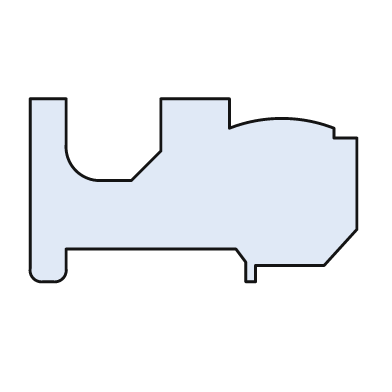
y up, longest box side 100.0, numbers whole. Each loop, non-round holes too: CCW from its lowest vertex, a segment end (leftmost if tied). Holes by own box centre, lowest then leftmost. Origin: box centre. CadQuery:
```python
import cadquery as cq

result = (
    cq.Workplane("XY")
    .moveTo(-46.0, -28.0)
    .lineTo(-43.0, -28.0)
    .threePointArc((-40.0, -27.0), (-39.0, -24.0))
    .lineTo(-39.0, -18.0)
    .lineTo(13.0, -18.0)
    .lineTo(16.0, -22.0)
    .lineTo(16.0, -28.0)
    .lineTo(19.0, -28.0)
    .lineTo(19.0, -23.0)
    .lineTo(40.0, -23.0)
    .lineTo(50.0, -12.0)
    .lineTo(50.0, 16.0)
    .lineTo(43.0, 16.0)
    .lineTo(43.0, 19.0)
    .threePointArc((27.0, 22.0), (11.0, 19.0))
    .lineTo(11.0, 28.0)
    .lineTo(-10.0, 28.0)
    .lineTo(-10.0, 12.0)
    .lineTo(-19.0, 3.0)
    .lineTo(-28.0, 3.0)
    .threePointArc((-36.0, 6.0), (-39.0, 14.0))
    .lineTo(-39.0, 28.0)
    .lineTo(-50.0, 28.0)
    .lineTo(-50.0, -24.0)
    .threePointArc((-49.0, -27.0), (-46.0, -28.0))
    .close()
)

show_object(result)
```